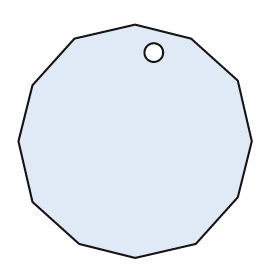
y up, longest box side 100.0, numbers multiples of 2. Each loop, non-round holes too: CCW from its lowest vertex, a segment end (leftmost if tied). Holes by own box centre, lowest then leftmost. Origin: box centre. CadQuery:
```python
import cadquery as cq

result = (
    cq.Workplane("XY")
    .moveTo(0.0, -50.0)
    .lineTo(26.0, -44.0)
    .lineTo(44.0, -24.0)
    .lineTo(50.0, 0.0)
    .lineTo(44.0, 26.0)
    .lineTo(24.0, 44.0)
    .lineTo(0.0, 50.0)
    .lineTo(-26.0, 44.0)
    .lineTo(-44.0, 24.0)
    .lineTo(-50.0, 0.0)
    .lineTo(-44.0, -26.0)
    .lineTo(-24.0, -44.0)
    .close()
    .moveTo(8.0, 38.0)
    .circle(4.0)
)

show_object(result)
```